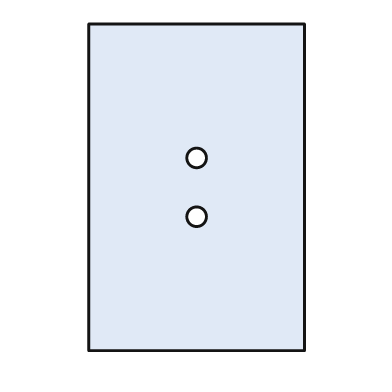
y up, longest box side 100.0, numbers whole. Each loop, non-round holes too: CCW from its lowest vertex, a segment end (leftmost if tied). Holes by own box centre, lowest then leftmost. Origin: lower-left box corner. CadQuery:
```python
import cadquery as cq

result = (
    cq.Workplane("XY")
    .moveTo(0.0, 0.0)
    .lineTo(66.0, 0.0)
    .lineTo(66.0, 100.0)
    .lineTo(0.0, 100.0)
    .close()
    .moveTo(33.0, 41.0)
    .circle(3.0)
    .moveTo(33.0, 59.0)
    .circle(3.0)
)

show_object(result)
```